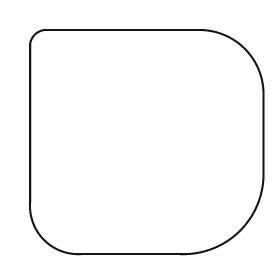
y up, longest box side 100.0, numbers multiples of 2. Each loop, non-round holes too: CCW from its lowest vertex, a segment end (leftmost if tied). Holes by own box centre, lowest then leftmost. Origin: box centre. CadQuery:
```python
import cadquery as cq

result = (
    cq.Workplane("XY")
    .moveTo(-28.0, -48.0)
    .lineTo(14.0, -48.0)
    .threePointArc((40.0, -38.0), (50.0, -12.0))
    .lineTo(50.0, 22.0)
    .threePointArc((42.0, 40.0), (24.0, 48.0))
    .lineTo(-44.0, 48.0)
    .threePointArc((-48.0, 46.0), (-50.0, 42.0))
    .lineTo(-50.0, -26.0)
    .threePointArc((-44.0, -42.0), (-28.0, -48.0))
    .close()
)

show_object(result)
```